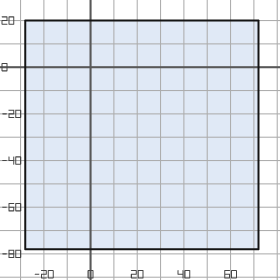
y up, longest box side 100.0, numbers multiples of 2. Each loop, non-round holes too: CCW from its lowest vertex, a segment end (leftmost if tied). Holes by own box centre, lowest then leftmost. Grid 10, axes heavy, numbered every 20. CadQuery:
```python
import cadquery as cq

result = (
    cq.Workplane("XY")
    .moveTo(-28.0, -78.0)
    .lineTo(72.0, -78.0)
    .lineTo(72.0, 20.0)
    .lineTo(-28.0, 20.0)
    .close()
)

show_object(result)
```